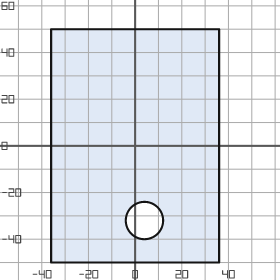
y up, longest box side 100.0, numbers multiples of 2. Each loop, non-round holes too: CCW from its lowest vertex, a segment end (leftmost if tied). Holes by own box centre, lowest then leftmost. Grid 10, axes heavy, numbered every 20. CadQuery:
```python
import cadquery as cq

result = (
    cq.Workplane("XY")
    .moveTo(-36.0, -50.0)
    .lineTo(36.0, -50.0)
    .lineTo(36.0, 50.0)
    .lineTo(-36.0, 50.0)
    .close()
    .moveTo(4.0, -32.0)
    .circle(8.0)
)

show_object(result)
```